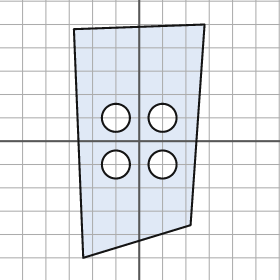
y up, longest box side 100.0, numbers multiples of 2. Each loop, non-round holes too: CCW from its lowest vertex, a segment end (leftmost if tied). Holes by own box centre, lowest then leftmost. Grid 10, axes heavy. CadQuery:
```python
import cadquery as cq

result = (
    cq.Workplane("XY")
    .moveTo(-24.0, -50.0)
    .lineTo(22.0, -36.0)
    .lineTo(28.0, 50.0)
    .lineTo(-28.0, 48.0)
    .close()
    .moveTo(-10.0, -10.0)
    .circle(6.0)
    .moveTo(10.0, -10.0)
    .circle(6.0)
    .moveTo(-10.0, 10.0)
    .circle(6.0)
    .moveTo(10.0, 10.0)
    .circle(6.0)
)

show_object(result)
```